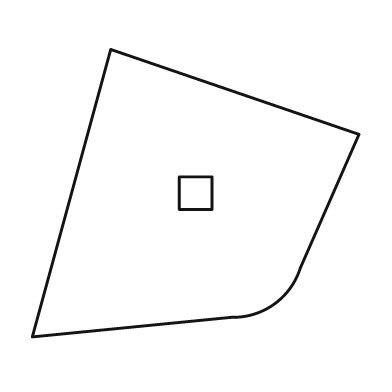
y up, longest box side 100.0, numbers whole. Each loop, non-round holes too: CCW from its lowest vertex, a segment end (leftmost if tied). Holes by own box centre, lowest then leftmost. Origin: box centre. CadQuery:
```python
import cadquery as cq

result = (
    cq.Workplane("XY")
    .moveTo(-50.0, -44.0)
    .lineTo(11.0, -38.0)
    .threePointArc((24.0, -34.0), (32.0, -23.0))
    .lineTo(50.0, 18.0)
    .lineTo(-26.0, 44.0)
    .close()
    .moveTo(-5.0, -5.0)
    .lineTo(5.0, -5.0)
    .lineTo(5.0, 5.0)
    .lineTo(-5.0, 5.0)
    .close()
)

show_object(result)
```